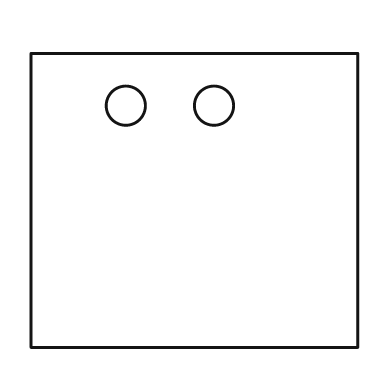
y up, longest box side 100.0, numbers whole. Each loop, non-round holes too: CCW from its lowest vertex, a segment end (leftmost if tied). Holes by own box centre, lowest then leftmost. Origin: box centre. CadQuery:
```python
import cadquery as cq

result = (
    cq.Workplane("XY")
    .moveTo(-50.0, -45.0)
    .lineTo(50.0, -45.0)
    .lineTo(50.0, 45.0)
    .lineTo(-50.0, 45.0)
    .close()
    .moveTo(-21.0, 29.0)
    .circle(6.0)
    .moveTo(6.0, 29.0)
    .circle(6.0)
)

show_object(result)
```